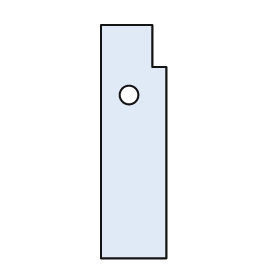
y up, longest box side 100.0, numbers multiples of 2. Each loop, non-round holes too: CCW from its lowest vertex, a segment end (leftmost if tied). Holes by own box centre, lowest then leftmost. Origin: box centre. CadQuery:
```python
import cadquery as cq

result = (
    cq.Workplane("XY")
    .moveTo(-14.0, -50.0)
    .lineTo(14.0, -50.0)
    .lineTo(14.0, 32.0)
    .lineTo(8.0, 32.0)
    .lineTo(8.0, 50.0)
    .lineTo(-14.0, 50.0)
    .close()
    .moveTo(-2.0, 20.0)
    .circle(4.0)
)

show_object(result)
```